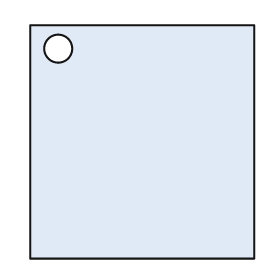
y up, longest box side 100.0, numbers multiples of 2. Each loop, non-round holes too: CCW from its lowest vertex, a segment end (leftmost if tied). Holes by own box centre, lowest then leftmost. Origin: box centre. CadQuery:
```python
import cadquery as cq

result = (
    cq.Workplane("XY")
    .moveTo(-48.0, -50.0)
    .lineTo(48.0, -50.0)
    .lineTo(48.0, 50.0)
    .lineTo(-48.0, 50.0)
    .close()
    .moveTo(-36.0, 40.0)
    .circle(6.0)
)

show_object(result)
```